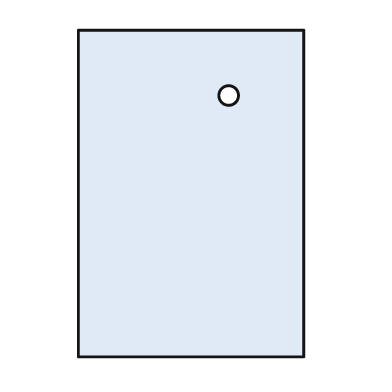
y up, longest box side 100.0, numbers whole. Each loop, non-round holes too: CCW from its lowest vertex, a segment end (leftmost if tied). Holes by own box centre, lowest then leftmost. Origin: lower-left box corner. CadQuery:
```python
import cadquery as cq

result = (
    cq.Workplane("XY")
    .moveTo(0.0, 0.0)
    .lineTo(69.0, 0.0)
    .lineTo(69.0, 100.0)
    .lineTo(0.0, 100.0)
    .close()
    .moveTo(46.0, 80.0)
    .circle(3.0)
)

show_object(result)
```